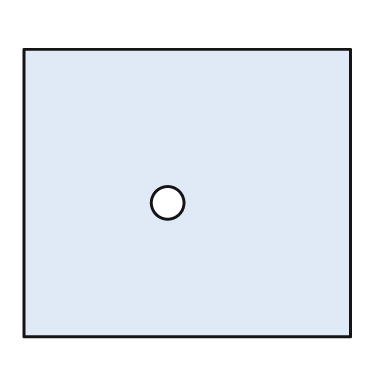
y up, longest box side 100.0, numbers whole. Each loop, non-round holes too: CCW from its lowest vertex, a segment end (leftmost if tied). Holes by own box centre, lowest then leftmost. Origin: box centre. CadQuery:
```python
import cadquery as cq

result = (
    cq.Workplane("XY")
    .moveTo(-50.0, -44.0)
    .lineTo(50.0, -44.0)
    .lineTo(50.0, 44.0)
    .lineTo(-50.0, 44.0)
    .close()
    .moveTo(-6.0, -3.0)
    .circle(5.0)
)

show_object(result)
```